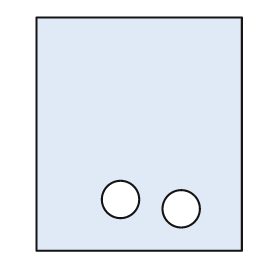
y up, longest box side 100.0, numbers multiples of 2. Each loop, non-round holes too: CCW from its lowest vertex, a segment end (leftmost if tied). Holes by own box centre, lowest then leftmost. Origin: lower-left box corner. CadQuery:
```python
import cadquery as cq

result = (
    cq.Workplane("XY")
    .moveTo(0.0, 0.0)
    .lineTo(88.0, 0.0)
    .lineTo(88.0, 100.0)
    .lineTo(0.0, 100.0)
    .close()
    .moveTo(62.0, 18.0)
    .circle(8.0)
    .moveTo(36.0, 22.0)
    .circle(8.0)
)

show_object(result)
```